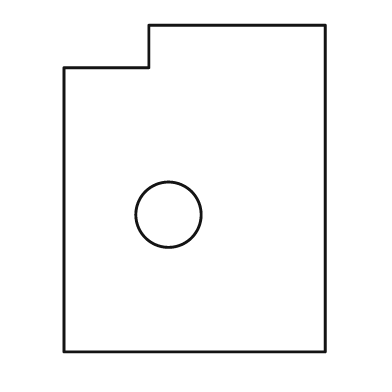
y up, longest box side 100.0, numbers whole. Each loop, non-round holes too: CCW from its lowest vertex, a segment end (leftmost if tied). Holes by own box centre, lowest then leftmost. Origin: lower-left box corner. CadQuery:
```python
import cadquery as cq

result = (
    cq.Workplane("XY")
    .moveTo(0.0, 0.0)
    .lineTo(80.0, 0.0)
    .lineTo(80.0, 100.0)
    .lineTo(26.0, 100.0)
    .lineTo(26.0, 87.0)
    .lineTo(0.0, 87.0)
    .close()
    .moveTo(32.0, 42.0)
    .circle(10.0)
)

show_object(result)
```